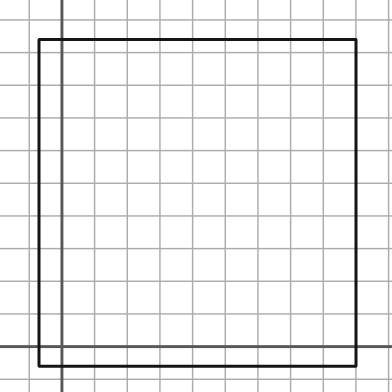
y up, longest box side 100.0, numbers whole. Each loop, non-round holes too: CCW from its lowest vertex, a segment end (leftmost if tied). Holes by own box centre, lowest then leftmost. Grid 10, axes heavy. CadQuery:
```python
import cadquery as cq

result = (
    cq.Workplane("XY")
    .moveTo(-7.0, -6.0)
    .lineTo(90.0, -6.0)
    .lineTo(90.0, 94.0)
    .lineTo(-7.0, 94.0)
    .close()
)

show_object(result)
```